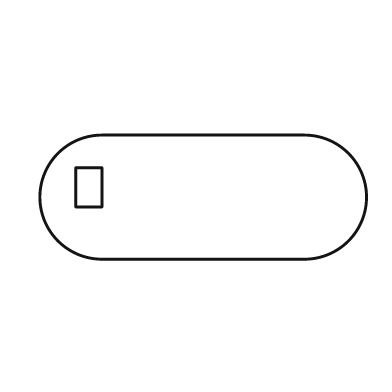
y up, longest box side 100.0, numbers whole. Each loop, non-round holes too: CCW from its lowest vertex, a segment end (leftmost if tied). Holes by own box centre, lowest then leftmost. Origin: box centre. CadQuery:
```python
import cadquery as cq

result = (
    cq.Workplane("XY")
    .moveTo(-31.0, -19.0)
    .lineTo(31.0, -19.0)
    .threePointArc((50.0, 0.0), (31.0, 19.0))
    .lineTo(-31.0, 19.0)
    .threePointArc((-50.0, 0.0), (-31.0, -19.0))
    .close()
    .moveTo(-39.0, -3.0)
    .lineTo(-31.0, -3.0)
    .lineTo(-31.0, 9.0)
    .lineTo(-39.0, 9.0)
    .close()
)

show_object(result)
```